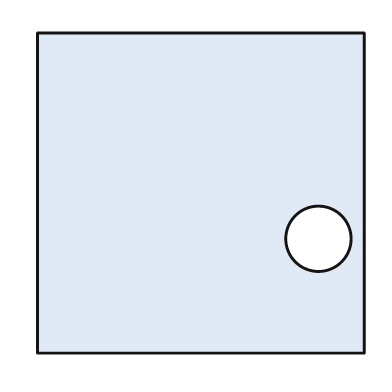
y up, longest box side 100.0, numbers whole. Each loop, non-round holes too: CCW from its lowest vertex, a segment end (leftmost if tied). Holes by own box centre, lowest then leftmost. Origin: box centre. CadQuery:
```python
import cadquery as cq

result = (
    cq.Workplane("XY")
    .moveTo(-50.0, -49.0)
    .lineTo(50.0, -49.0)
    .lineTo(50.0, 49.0)
    .lineTo(-50.0, 49.0)
    .close()
    .moveTo(36.0, -14.0)
    .circle(10.0)
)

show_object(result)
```